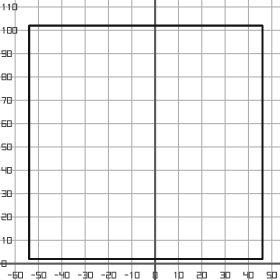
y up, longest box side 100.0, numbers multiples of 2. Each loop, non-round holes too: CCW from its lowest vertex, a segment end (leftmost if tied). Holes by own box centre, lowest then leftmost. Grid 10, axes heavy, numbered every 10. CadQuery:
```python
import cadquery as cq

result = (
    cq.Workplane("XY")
    .moveTo(-54.0, 2.0)
    .lineTo(46.0, 2.0)
    .lineTo(46.0, 102.0)
    .lineTo(-54.0, 102.0)
    .close()
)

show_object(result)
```